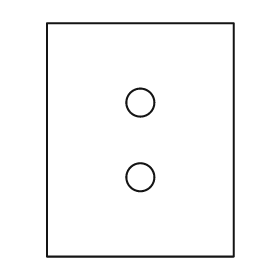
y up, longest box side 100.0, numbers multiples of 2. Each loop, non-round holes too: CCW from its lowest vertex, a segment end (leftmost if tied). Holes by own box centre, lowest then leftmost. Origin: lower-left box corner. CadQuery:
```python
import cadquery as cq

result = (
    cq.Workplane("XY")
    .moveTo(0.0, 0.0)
    .lineTo(80.0, 0.0)
    .lineTo(80.0, 100.0)
    .lineTo(0.0, 100.0)
    .close()
    .moveTo(40.0, 34.0)
    .circle(6.0)
    .moveTo(40.0, 66.0)
    .circle(6.0)
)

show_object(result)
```